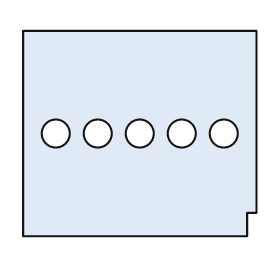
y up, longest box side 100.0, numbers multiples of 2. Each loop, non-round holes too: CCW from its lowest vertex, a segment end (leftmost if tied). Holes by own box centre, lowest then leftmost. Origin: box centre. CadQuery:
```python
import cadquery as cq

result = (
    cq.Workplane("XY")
    .moveTo(-50.0, -44.0)
    .lineTo(46.0, -44.0)
    .lineTo(46.0, -34.0)
    .lineTo(50.0, -34.0)
    .lineTo(50.0, 44.0)
    .lineTo(-50.0, 44.0)
    .close()
    .moveTo(-36.0, 0.0)
    .circle(6.0)
    .moveTo(-18.0, 0.0)
    .circle(6.0)
    .moveTo(0.0, 0.0)
    .circle(6.0)
    .moveTo(18.0, 0.0)
    .circle(6.0)
    .moveTo(36.0, 0.0)
    .circle(6.0)
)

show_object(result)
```